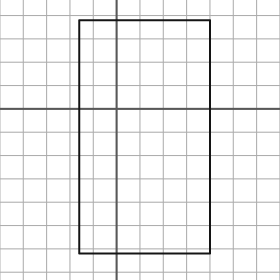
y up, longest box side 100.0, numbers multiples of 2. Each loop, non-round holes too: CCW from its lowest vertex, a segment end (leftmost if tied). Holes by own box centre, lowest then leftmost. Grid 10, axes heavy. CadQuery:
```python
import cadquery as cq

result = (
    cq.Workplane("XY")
    .moveTo(-16.0, -62.0)
    .lineTo(40.0, -62.0)
    .lineTo(40.0, 38.0)
    .lineTo(-16.0, 38.0)
    .close()
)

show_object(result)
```